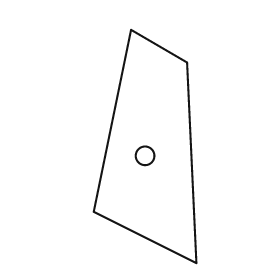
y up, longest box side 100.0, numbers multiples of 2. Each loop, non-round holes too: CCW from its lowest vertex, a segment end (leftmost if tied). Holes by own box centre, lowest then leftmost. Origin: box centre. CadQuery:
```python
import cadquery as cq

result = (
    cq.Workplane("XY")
    .moveTo(22.0, -50.0)
    .lineTo(18.0, 36.0)
    .lineTo(-6.0, 50.0)
    .lineTo(-22.0, -28.0)
    .close()
    .moveTo(0.0, -4.0)
    .circle(4.0)
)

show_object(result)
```